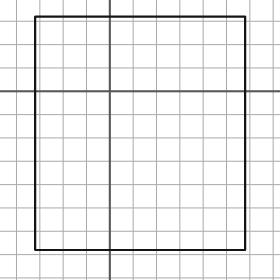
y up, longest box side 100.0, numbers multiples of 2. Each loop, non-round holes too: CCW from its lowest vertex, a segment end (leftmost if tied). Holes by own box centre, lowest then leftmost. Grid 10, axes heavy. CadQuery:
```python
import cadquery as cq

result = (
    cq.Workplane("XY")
    .moveTo(-32.0, -68.0)
    .lineTo(58.0, -68.0)
    .lineTo(58.0, 32.0)
    .lineTo(-32.0, 32.0)
    .close()
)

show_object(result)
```